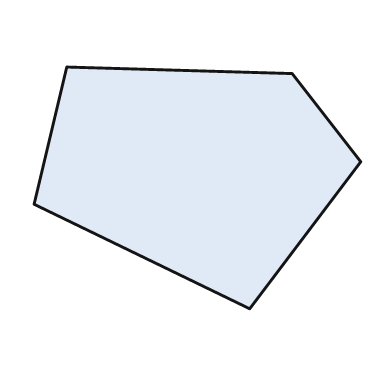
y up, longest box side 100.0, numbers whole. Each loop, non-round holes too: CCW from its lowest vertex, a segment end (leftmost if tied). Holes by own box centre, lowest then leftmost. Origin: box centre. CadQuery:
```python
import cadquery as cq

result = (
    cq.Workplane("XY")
    .moveTo(16.0, -37.0)
    .lineTo(50.0, 8.0)
    .lineTo(29.0, 35.0)
    .lineTo(-40.0, 37.0)
    .lineTo(-50.0, -5.0)
    .close()
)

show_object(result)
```